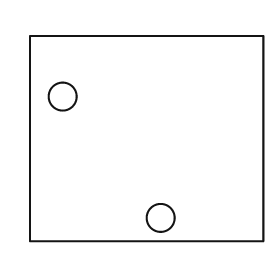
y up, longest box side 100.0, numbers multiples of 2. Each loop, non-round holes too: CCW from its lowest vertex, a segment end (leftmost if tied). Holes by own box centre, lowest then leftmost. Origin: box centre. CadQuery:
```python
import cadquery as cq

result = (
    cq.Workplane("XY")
    .moveTo(-50.0, -44.0)
    .lineTo(50.0, -44.0)
    .lineTo(50.0, 44.0)
    .lineTo(-50.0, 44.0)
    .close()
    .moveTo(6.0, -34.0)
    .circle(6.0)
    .moveTo(-36.0, 18.0)
    .circle(6.0)
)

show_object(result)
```